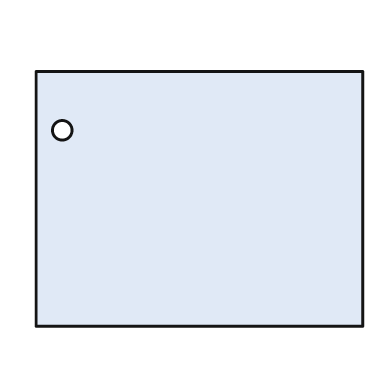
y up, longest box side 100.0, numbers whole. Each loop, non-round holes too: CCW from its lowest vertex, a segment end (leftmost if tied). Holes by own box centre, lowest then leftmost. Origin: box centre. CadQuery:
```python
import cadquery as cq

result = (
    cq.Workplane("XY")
    .moveTo(-50.0, -39.0)
    .lineTo(50.0, -39.0)
    .lineTo(50.0, 39.0)
    .lineTo(-50.0, 39.0)
    .close()
    .moveTo(-42.0, 21.0)
    .circle(3.0)
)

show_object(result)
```